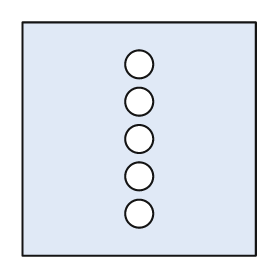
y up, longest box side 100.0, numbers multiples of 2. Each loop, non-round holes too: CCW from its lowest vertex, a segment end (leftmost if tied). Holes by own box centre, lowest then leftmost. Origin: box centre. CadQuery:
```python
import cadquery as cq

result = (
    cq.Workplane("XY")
    .moveTo(-50.0, -50.0)
    .lineTo(50.0, -50.0)
    .lineTo(50.0, 50.0)
    .lineTo(-50.0, 50.0)
    .close()
    .moveTo(0.0, -32.0)
    .circle(6.0)
    .moveTo(0.0, -16.0)
    .circle(6.0)
    .moveTo(0.0, 0.0)
    .circle(6.0)
    .moveTo(0.0, 16.0)
    .circle(6.0)
    .moveTo(0.0, 32.0)
    .circle(6.0)
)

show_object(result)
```